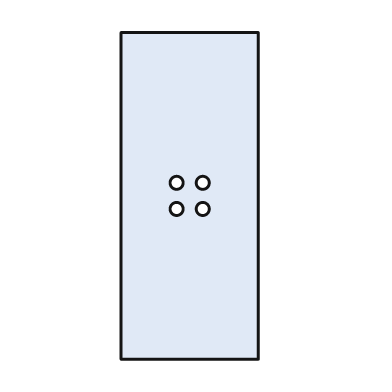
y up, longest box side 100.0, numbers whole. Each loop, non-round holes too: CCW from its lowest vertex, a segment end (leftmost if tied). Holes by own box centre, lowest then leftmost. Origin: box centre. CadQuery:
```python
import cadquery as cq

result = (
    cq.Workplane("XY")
    .moveTo(-21.0, -50.0)
    .lineTo(21.0, -50.0)
    .lineTo(21.0, 50.0)
    .lineTo(-21.0, 50.0)
    .close()
    .moveTo(-4.0, -4.0)
    .circle(2.0)
    .moveTo(4.0, -4.0)
    .circle(2.0)
    .moveTo(-4.0, 4.0)
    .circle(2.0)
    .moveTo(4.0, 4.0)
    .circle(2.0)
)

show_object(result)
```